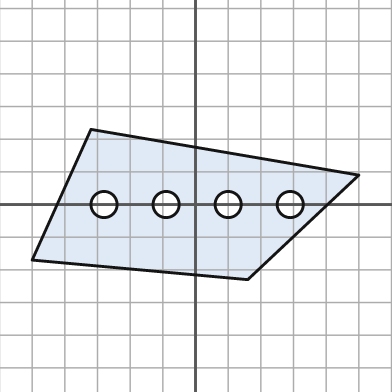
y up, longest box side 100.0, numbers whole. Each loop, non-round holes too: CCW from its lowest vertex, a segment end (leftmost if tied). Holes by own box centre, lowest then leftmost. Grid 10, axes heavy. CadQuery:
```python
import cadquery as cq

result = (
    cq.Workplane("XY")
    .moveTo(16.0, -23.0)
    .lineTo(50.0, 9.0)
    .lineTo(-32.0, 23.0)
    .lineTo(-50.0, -17.0)
    .close()
    .moveTo(-28.0, 0.0)
    .circle(4.0)
    .moveTo(-9.0, 0.0)
    .circle(4.0)
    .moveTo(10.0, 0.0)
    .circle(4.0)
    .moveTo(29.0, 0.0)
    .circle(4.0)
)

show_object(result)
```